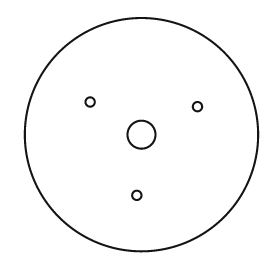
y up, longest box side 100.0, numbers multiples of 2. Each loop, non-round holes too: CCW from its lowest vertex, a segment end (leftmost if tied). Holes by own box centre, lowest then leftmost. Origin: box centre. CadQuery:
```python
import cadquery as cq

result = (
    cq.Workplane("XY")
    .moveTo(0.0, 0.0)
    .circle(50.0)
    .moveTo(-2.0, -26.0)
    .circle(2.0)
    .moveTo(0.0, 0.0)
    .circle(6.0)
    .moveTo(24.0, 12.0)
    .circle(2.0)
    .moveTo(-22.0, 14.0)
    .circle(2.0)
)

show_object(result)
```